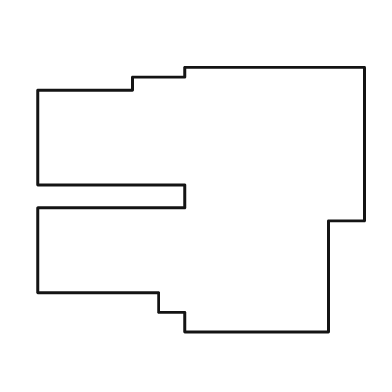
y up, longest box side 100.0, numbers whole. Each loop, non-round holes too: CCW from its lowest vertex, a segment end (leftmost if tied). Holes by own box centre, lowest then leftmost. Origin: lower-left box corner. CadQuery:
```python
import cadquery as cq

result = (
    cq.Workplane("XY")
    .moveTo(45.0, 0.0)
    .lineTo(89.0, 0.0)
    .lineTo(89.0, 34.0)
    .lineTo(100.0, 34.0)
    .lineTo(100.0, 81.0)
    .lineTo(45.0, 81.0)
    .lineTo(45.0, 78.0)
    .lineTo(29.0, 78.0)
    .lineTo(29.0, 74.0)
    .lineTo(0.0, 74.0)
    .lineTo(0.0, 45.0)
    .lineTo(45.0, 45.0)
    .lineTo(45.0, 38.0)
    .lineTo(0.0, 38.0)
    .lineTo(0.0, 12.0)
    .lineTo(37.0, 12.0)
    .lineTo(37.0, 6.0)
    .lineTo(45.0, 6.0)
    .close()
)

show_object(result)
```